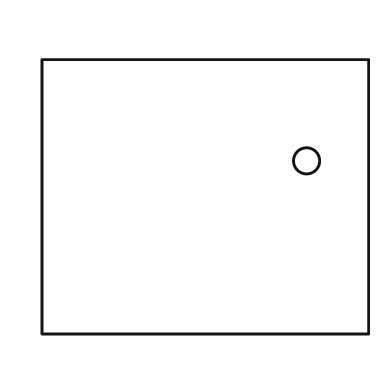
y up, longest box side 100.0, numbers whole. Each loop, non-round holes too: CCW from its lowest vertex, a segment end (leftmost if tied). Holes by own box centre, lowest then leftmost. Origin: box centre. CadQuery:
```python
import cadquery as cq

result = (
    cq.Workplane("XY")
    .moveTo(-50.0, -42.0)
    .lineTo(50.0, -42.0)
    .lineTo(50.0, 42.0)
    .lineTo(-50.0, 42.0)
    .close()
    .moveTo(31.0, 11.0)
    .circle(4.0)
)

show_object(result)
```